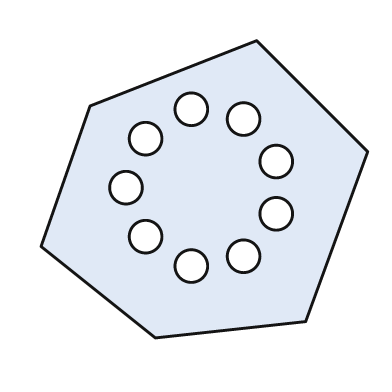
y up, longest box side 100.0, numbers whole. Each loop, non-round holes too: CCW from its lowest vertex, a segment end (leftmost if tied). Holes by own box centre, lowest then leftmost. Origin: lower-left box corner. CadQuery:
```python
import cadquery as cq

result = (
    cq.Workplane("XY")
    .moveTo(35.0, 0.0)
    .lineTo(81.0, 5.0)
    .lineTo(100.0, 57.0)
    .lineTo(66.0, 91.0)
    .lineTo(15.0, 71.0)
    .lineTo(0.0, 28.0)
    .close()
    .moveTo(46.0, 22.0)
    .circle(5.0)
    .moveTo(62.0, 25.0)
    .circle(5.0)
    .moveTo(32.0, 31.0)
    .circle(5.0)
    .moveTo(72.0, 38.0)
    .circle(5.0)
    .moveTo(26.0, 46.0)
    .circle(5.0)
    .moveTo(72.0, 54.0)
    .circle(5.0)
    .moveTo(32.0, 61.0)
    .circle(5.0)
    .moveTo(62.0, 67.0)
    .circle(5.0)
    .moveTo(46.0, 70.0)
    .circle(5.0)
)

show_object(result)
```